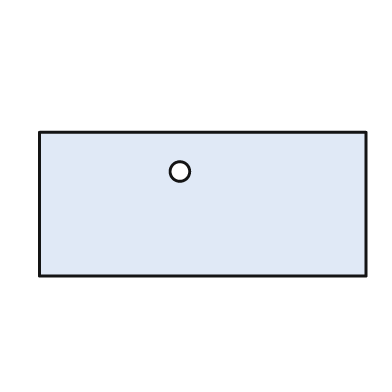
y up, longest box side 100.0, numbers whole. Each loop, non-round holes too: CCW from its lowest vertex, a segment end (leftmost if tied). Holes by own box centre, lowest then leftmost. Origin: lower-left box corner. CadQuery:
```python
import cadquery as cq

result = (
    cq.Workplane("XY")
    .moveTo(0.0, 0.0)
    .lineTo(100.0, 0.0)
    .lineTo(100.0, 44.0)
    .lineTo(0.0, 44.0)
    .close()
    .moveTo(43.0, 32.0)
    .circle(3.0)
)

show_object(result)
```